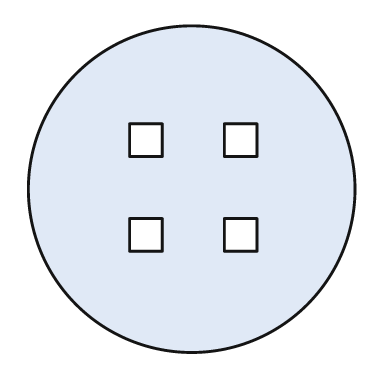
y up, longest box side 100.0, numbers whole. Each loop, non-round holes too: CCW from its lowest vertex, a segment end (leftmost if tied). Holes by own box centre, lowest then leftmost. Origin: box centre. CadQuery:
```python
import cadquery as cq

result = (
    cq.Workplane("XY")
    .moveTo(0.0, 0.0)
    .circle(50.0)
    .moveTo(-19.0, -19.0)
    .lineTo(-9.0, -19.0)
    .lineTo(-9.0, -9.0)
    .lineTo(-19.0, -9.0)
    .close()
    .moveTo(10.0, -19.0)
    .lineTo(20.0, -19.0)
    .lineTo(20.0, -9.0)
    .lineTo(10.0, -9.0)
    .close()
    .moveTo(-19.0, 10.0)
    .lineTo(-9.0, 10.0)
    .lineTo(-9.0, 20.0)
    .lineTo(-19.0, 20.0)
    .close()
    .moveTo(10.0, 10.0)
    .lineTo(20.0, 10.0)
    .lineTo(20.0, 20.0)
    .lineTo(10.0, 20.0)
    .close()
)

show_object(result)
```